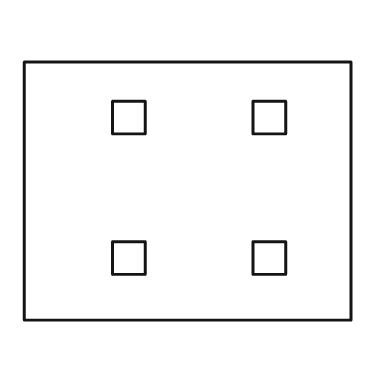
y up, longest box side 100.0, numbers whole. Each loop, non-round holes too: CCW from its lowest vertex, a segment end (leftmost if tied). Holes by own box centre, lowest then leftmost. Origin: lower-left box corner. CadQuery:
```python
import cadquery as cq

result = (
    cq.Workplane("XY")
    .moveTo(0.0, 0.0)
    .lineTo(100.0, 0.0)
    .lineTo(100.0, 79.0)
    .lineTo(0.0, 79.0)
    .close()
    .moveTo(27.0, 14.0)
    .lineTo(37.0, 14.0)
    .lineTo(37.0, 24.0)
    .lineTo(27.0, 24.0)
    .close()
    .moveTo(70.0, 14.0)
    .lineTo(80.0, 14.0)
    .lineTo(80.0, 24.0)
    .lineTo(70.0, 24.0)
    .close()
    .moveTo(27.0, 57.0)
    .lineTo(37.0, 57.0)
    .lineTo(37.0, 67.0)
    .lineTo(27.0, 67.0)
    .close()
    .moveTo(70.0, 57.0)
    .lineTo(80.0, 57.0)
    .lineTo(80.0, 67.0)
    .lineTo(70.0, 67.0)
    .close()
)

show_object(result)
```